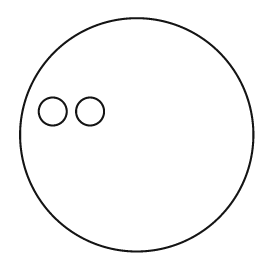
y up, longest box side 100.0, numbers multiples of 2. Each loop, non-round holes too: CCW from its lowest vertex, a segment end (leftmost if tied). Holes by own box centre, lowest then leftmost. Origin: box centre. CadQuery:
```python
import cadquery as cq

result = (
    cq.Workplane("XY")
    .moveTo(0.0, 0.0)
    .circle(50.0)
    .moveTo(-36.0, 10.0)
    .circle(6.0)
    .moveTo(-20.0, 10.0)
    .circle(6.0)
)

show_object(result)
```